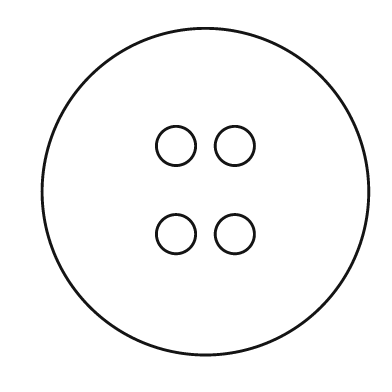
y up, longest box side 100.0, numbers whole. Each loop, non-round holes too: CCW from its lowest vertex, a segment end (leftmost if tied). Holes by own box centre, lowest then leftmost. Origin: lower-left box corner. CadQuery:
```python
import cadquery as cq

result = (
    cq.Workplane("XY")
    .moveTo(50.0, 50.0)
    .circle(50.0)
    .moveTo(41.0, 37.0)
    .circle(6.0)
    .moveTo(59.0, 37.0)
    .circle(6.0)
    .moveTo(41.0, 64.0)
    .circle(6.0)
    .moveTo(59.0, 64.0)
    .circle(6.0)
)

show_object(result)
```